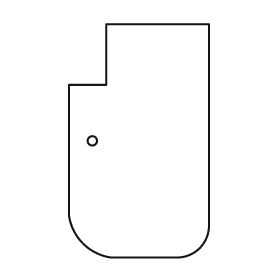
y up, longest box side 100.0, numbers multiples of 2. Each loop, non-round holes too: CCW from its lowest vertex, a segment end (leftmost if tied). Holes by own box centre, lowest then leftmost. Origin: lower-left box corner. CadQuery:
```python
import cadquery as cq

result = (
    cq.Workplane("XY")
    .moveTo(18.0, 0.0)
    .lineTo(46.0, 0.0)
    .threePointArc((56.0, 4.0), (60.0, 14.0))
    .lineTo(60.0, 100.0)
    .lineTo(16.0, 100.0)
    .lineTo(16.0, 74.0)
    .lineTo(0.0, 74.0)
    .lineTo(0.0, 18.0)
    .threePointArc((6.0, 6.0), (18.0, 0.0))
    .close()
    .moveTo(10.0, 50.0)
    .circle(2.0)
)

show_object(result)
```